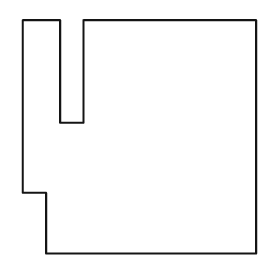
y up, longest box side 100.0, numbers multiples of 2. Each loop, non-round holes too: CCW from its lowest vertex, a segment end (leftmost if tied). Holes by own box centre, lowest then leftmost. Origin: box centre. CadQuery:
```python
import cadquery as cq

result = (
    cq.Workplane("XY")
    .moveTo(-40.0, -50.0)
    .lineTo(50.0, -50.0)
    .lineTo(50.0, 50.0)
    .lineTo(-24.0, 50.0)
    .lineTo(-24.0, 6.0)
    .lineTo(-34.0, 6.0)
    .lineTo(-34.0, 50.0)
    .lineTo(-50.0, 50.0)
    .lineTo(-50.0, -24.0)
    .lineTo(-40.0, -24.0)
    .close()
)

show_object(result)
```